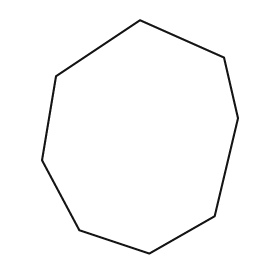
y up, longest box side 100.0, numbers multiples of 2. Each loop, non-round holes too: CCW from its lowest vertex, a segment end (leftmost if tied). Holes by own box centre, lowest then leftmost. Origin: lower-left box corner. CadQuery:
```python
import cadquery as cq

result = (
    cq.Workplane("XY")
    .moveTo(46.0, 0.0)
    .lineTo(74.0, 16.0)
    .lineTo(84.0, 58.0)
    .lineTo(78.0, 84.0)
    .lineTo(42.0, 100.0)
    .lineTo(6.0, 76.0)
    .lineTo(0.0, 40.0)
    .lineTo(16.0, 10.0)
    .close()
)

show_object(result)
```